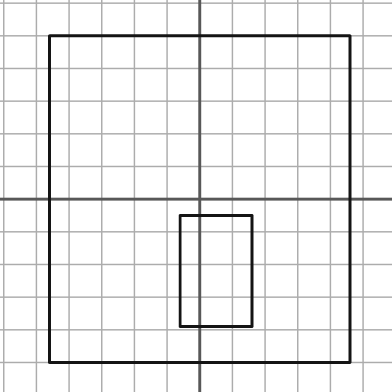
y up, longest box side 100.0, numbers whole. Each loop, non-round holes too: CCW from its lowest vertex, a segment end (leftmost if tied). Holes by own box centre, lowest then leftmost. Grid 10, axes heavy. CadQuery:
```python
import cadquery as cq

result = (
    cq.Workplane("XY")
    .moveTo(-46.0, -50.0)
    .lineTo(46.0, -50.0)
    .lineTo(46.0, 50.0)
    .lineTo(-46.0, 50.0)
    .close()
    .moveTo(-6.0, -39.0)
    .lineTo(16.0, -39.0)
    .lineTo(16.0, -5.0)
    .lineTo(-6.0, -5.0)
    .close()
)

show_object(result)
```